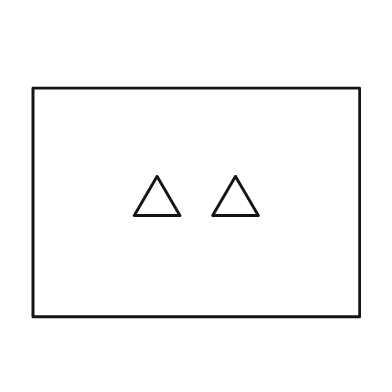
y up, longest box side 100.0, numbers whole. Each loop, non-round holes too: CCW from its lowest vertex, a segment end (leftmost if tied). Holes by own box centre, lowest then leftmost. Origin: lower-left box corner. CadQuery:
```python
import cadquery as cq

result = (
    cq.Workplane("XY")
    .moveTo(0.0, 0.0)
    .lineTo(100.0, 0.0)
    .lineTo(100.0, 70.0)
    .lineTo(0.0, 70.0)
    .close()
    .moveTo(31.0, 31.0)
    .lineTo(45.0, 31.0)
    .lineTo(38.0, 43.0)
    .close()
    .moveTo(55.0, 31.0)
    .lineTo(69.0, 31.0)
    .lineTo(62.0, 43.0)
    .close()
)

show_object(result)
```